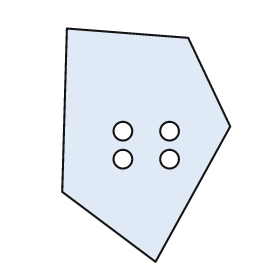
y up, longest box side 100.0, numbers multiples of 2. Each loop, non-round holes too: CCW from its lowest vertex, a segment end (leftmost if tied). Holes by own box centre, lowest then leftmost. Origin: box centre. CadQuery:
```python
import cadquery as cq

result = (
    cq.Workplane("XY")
    .moveTo(4.0, -50.0)
    .lineTo(36.0, 8.0)
    .lineTo(18.0, 46.0)
    .lineTo(-34.0, 50.0)
    .lineTo(-36.0, -20.0)
    .close()
    .moveTo(-10.0, -6.0)
    .circle(4.0)
    .moveTo(10.0, -6.0)
    .circle(4.0)
    .moveTo(-10.0, 6.0)
    .circle(4.0)
    .moveTo(10.0, 6.0)
    .circle(4.0)
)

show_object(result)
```